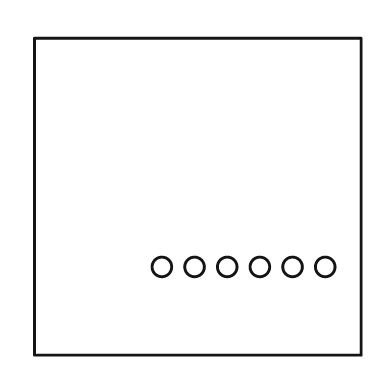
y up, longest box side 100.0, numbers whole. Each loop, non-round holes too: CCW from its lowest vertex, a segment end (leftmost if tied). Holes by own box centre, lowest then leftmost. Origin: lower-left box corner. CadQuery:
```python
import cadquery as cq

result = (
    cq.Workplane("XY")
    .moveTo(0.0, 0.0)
    .lineTo(100.0, 0.0)
    .lineTo(100.0, 97.0)
    .lineTo(0.0, 97.0)
    .close()
    .moveTo(39.0, 27.0)
    .circle(3.0)
    .moveTo(49.0, 27.0)
    .circle(3.0)
    .moveTo(59.0, 27.0)
    .circle(3.0)
    .moveTo(69.0, 27.0)
    .circle(3.0)
    .moveTo(79.0, 27.0)
    .circle(3.0)
    .moveTo(89.0, 27.0)
    .circle(3.0)
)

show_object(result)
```